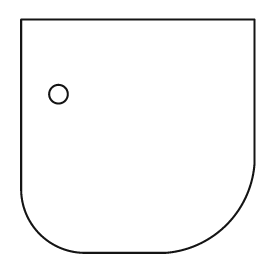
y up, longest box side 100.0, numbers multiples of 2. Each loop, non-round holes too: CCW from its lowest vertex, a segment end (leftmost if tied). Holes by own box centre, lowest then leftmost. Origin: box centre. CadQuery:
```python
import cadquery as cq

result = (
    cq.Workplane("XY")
    .moveTo(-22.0, -50.0)
    .lineTo(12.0, -50.0)
    .threePointArc((38.0, -38.0), (50.0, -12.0))
    .lineTo(50.0, 50.0)
    .lineTo(-50.0, 50.0)
    .lineTo(-50.0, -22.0)
    .threePointArc((-42.0, -42.0), (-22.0, -50.0))
    .close()
    .moveTo(-34.0, 18.0)
    .circle(4.0)
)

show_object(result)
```